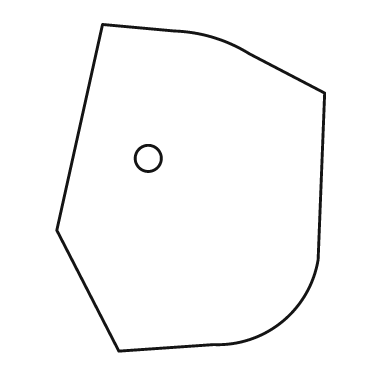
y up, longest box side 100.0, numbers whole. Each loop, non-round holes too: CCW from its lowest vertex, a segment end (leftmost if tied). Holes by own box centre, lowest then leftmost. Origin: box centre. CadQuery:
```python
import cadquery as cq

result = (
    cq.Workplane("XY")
    .moveTo(-22.0, -50.0)
    .lineTo(7.0, -48.0)
    .threePointArc((28.0, -41.0), (39.0, -22.0))
    .lineTo(41.0, 29.0)
    .lineTo(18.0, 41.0)
    .threePointArc((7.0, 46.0), (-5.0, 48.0))
    .lineTo(-27.0, 50.0)
    .lineTo(-41.0, -13.0)
    .close()
    .moveTo(-13.0, 9.0)
    .circle(4.0)
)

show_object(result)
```